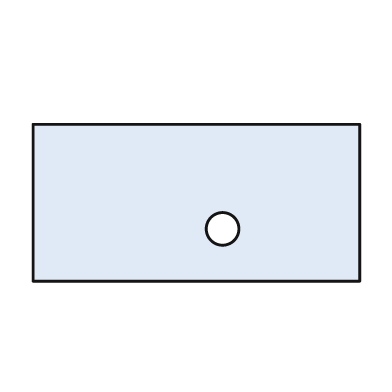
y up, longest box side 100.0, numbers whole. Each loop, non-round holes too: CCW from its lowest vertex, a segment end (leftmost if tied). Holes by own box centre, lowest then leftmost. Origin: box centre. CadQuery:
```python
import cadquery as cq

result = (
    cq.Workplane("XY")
    .moveTo(-50.0, -24.0)
    .lineTo(50.0, -24.0)
    .lineTo(50.0, 24.0)
    .lineTo(-50.0, 24.0)
    .close()
    .moveTo(8.0, -8.0)
    .circle(5.0)
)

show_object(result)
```